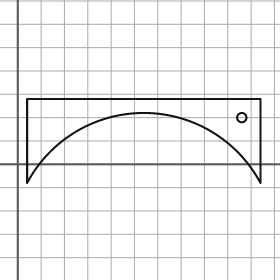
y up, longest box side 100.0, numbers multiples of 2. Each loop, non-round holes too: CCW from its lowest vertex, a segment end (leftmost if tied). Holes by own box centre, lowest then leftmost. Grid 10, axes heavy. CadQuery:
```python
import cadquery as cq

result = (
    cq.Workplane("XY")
    .moveTo(4.0, -8.0)
    .threePointArc((54.0, 22.0), (104.0, -8.0))
    .lineTo(104.0, 28.0)
    .lineTo(4.0, 28.0)
    .close()
    .moveTo(96.0, 20.0)
    .circle(2.0)
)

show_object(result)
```